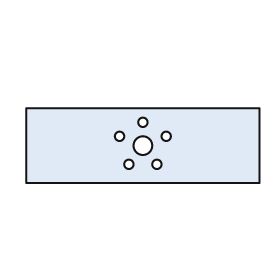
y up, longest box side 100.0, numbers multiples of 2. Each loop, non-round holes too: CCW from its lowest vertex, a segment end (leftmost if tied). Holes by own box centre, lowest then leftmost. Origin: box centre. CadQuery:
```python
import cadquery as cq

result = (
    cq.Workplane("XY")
    .moveTo(-50.0, -16.0)
    .lineTo(50.0, -16.0)
    .lineTo(50.0, 16.0)
    .lineTo(-50.0, 16.0)
    .close()
    .moveTo(-6.0, -8.0)
    .circle(2.0)
    .moveTo(6.0, -8.0)
    .circle(2.0)
    .moveTo(0.0, 0.0)
    .circle(4.0)
    .moveTo(-10.0, 4.0)
    .circle(2.0)
    .moveTo(10.0, 4.0)
    .circle(2.0)
    .moveTo(0.0, 10.0)
    .circle(2.0)
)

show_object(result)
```